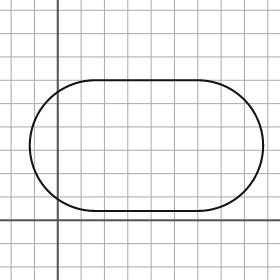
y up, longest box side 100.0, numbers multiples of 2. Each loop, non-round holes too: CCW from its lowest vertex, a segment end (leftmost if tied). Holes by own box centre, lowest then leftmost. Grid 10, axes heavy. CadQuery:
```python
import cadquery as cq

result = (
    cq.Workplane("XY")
    .moveTo(16.0, 4.0)
    .lineTo(60.0, 4.0)
    .threePointArc((88.0, 32.0), (60.0, 60.0))
    .lineTo(16.0, 60.0)
    .threePointArc((-12.0, 32.0), (16.0, 4.0))
    .close()
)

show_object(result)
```